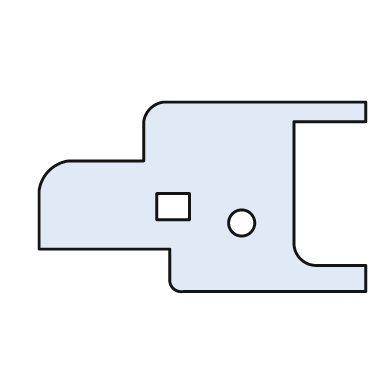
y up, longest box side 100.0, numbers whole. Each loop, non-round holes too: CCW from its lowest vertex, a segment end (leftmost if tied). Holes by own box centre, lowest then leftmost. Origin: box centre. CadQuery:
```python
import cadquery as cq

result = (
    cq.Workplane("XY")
    .moveTo(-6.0, -29.0)
    .lineTo(50.0, -29.0)
    .lineTo(50.0, -21.0)
    .lineTo(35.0, -21.0)
    .threePointArc((30.0, -19.0), (28.0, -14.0))
    .lineTo(28.0, 23.0)
    .lineTo(50.0, 23.0)
    .lineTo(50.0, 29.0)
    .lineTo(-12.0, 29.0)
    .threePointArc((-16.0, 27.0), (-18.0, 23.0))
    .lineTo(-18.0, 11.0)
    .lineTo(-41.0, 11.0)
    .threePointArc((-47.0, 8.0), (-50.0, 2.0))
    .lineTo(-50.0, -16.0)
    .lineTo(-10.0, -16.0)
    .lineTo(-10.0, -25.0)
    .threePointArc((-9.0, -28.0), (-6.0, -29.0))
    .close()
    .moveTo(12.0, -8.0)
    .circle(4.0)
    .moveTo(-14.0, -7.0)
    .lineTo(-4.0, -7.0)
    .lineTo(-4.0, 1.0)
    .lineTo(-14.0, 1.0)
    .close()
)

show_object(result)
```